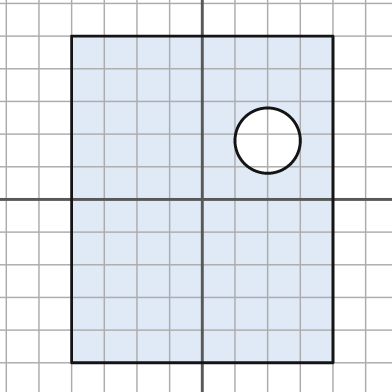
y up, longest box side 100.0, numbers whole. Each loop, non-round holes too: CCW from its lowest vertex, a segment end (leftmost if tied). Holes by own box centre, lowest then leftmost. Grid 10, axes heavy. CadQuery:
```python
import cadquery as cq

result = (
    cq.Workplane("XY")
    .moveTo(-40.0, -50.0)
    .lineTo(40.0, -50.0)
    .lineTo(40.0, 50.0)
    .lineTo(-40.0, 50.0)
    .close()
    .moveTo(20.0, 18.0)
    .circle(10.0)
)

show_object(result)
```